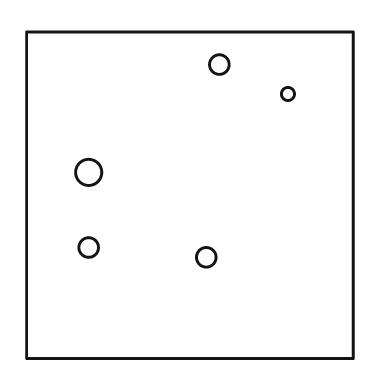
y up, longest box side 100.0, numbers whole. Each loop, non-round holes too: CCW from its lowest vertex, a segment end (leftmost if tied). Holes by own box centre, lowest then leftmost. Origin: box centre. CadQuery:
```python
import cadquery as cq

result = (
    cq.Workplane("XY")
    .moveTo(-50.0, -50.0)
    .lineTo(50.0, -50.0)
    .lineTo(50.0, 50.0)
    .lineTo(-50.0, 50.0)
    .close()
    .moveTo(5.0, -19.0)
    .circle(3.0)
    .moveTo(-31.0, -16.0)
    .circle(3.0)
    .moveTo(-31.0, 7.0)
    .circle(4.0)
    .moveTo(30.0, 31.0)
    .circle(2.0)
    .moveTo(9.0, 40.0)
    .circle(3.0)
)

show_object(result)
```